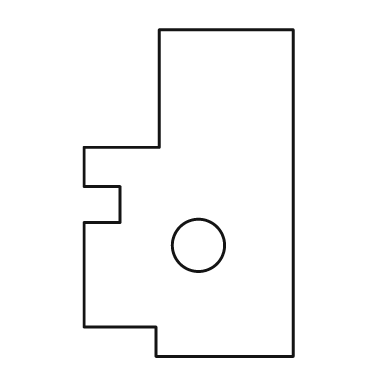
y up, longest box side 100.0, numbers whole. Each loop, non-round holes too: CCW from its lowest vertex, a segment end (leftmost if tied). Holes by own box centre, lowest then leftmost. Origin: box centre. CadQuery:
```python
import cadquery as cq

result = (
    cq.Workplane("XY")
    .moveTo(-10.0, -50.0)
    .lineTo(32.0, -50.0)
    .lineTo(32.0, 50.0)
    .lineTo(-9.0, 50.0)
    .lineTo(-9.0, 14.0)
    .lineTo(-32.0, 14.0)
    .lineTo(-32.0, 2.0)
    .lineTo(-21.0, 2.0)
    .lineTo(-21.0, -9.0)
    .lineTo(-32.0, -9.0)
    .lineTo(-32.0, -41.0)
    .lineTo(-10.0, -41.0)
    .close()
    .moveTo(3.0, -16.0)
    .circle(8.0)
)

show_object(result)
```